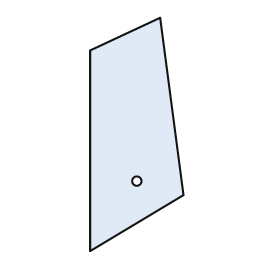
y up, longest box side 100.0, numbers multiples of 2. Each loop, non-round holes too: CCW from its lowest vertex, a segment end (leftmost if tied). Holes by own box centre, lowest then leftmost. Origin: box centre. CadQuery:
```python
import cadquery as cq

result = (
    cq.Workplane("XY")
    .moveTo(-20.0, -50.0)
    .lineTo(20.0, -26.0)
    .lineTo(10.0, 50.0)
    .lineTo(-20.0, 36.0)
    .close()
    .moveTo(0.0, -20.0)
    .circle(2.0)
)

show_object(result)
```